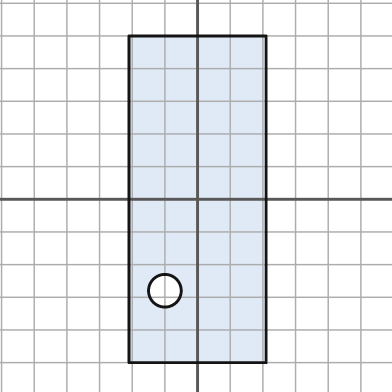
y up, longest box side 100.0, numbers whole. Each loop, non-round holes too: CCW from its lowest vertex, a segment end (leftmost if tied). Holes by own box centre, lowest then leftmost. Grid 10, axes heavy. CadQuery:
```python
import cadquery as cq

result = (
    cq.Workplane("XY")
    .moveTo(-21.0, -50.0)
    .lineTo(21.0, -50.0)
    .lineTo(21.0, 50.0)
    .lineTo(-21.0, 50.0)
    .close()
    .moveTo(-10.0, -28.0)
    .circle(5.0)
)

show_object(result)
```